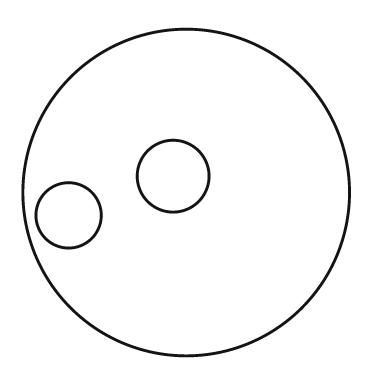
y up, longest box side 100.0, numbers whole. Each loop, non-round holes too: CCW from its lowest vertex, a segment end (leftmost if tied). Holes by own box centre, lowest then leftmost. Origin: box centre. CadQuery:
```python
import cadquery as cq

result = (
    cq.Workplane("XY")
    .moveTo(0.0, 0.0)
    .circle(50.0)
    .moveTo(-36.0, -7.0)
    .circle(10.0)
    .moveTo(-4.0, 5.0)
    .circle(11.0)
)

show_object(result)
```